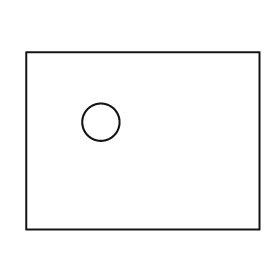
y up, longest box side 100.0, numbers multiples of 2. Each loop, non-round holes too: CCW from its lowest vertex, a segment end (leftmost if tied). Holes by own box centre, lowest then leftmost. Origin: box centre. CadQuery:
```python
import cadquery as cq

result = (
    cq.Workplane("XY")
    .moveTo(-50.0, -38.0)
    .lineTo(50.0, -38.0)
    .lineTo(50.0, 38.0)
    .lineTo(-50.0, 38.0)
    .close()
    .moveTo(-18.0, 8.0)
    .circle(8.0)
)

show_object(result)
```